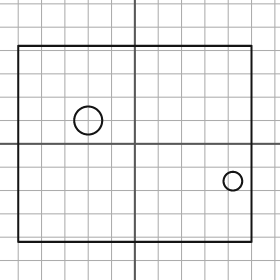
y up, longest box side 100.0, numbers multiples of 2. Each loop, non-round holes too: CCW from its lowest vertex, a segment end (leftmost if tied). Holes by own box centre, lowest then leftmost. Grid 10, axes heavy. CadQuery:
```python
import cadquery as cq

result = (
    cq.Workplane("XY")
    .moveTo(-50.0, -42.0)
    .lineTo(50.0, -42.0)
    .lineTo(50.0, 42.0)
    .lineTo(-50.0, 42.0)
    .close()
    .moveTo(42.0, -16.0)
    .circle(4.0)
    .moveTo(-20.0, 10.0)
    .circle(6.0)
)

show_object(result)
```